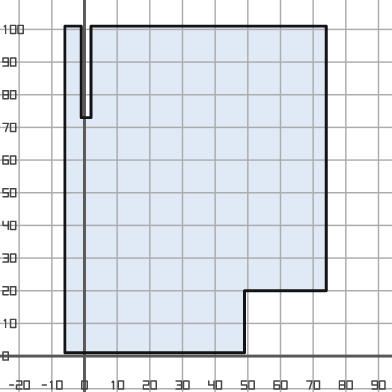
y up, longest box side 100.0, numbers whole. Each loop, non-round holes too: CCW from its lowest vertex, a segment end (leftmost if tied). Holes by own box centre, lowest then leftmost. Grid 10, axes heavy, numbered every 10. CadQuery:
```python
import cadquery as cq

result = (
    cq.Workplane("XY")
    .moveTo(-6.0, 1.0)
    .lineTo(49.0, 1.0)
    .lineTo(49.0, 20.0)
    .lineTo(74.0, 20.0)
    .lineTo(74.0, 101.0)
    .lineTo(2.0, 101.0)
    .lineTo(2.0, 73.0)
    .lineTo(-1.0, 73.0)
    .lineTo(-1.0, 101.0)
    .lineTo(-6.0, 101.0)
    .close()
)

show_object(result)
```